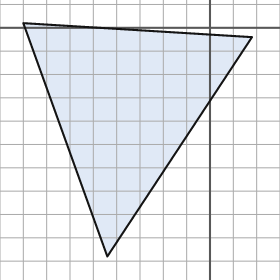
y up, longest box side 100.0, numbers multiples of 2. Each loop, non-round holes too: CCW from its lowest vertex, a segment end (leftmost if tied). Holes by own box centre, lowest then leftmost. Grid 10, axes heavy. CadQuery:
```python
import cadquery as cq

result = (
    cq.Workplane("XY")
    .moveTo(-44.0, -98.0)
    .lineTo(18.0, -4.0)
    .lineTo(-80.0, 2.0)
    .close()
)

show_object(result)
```